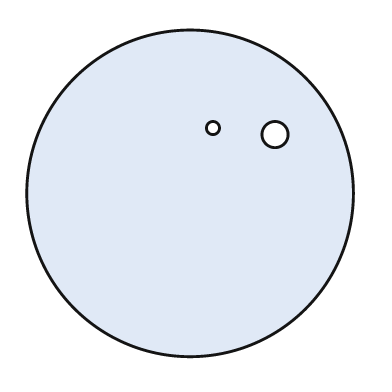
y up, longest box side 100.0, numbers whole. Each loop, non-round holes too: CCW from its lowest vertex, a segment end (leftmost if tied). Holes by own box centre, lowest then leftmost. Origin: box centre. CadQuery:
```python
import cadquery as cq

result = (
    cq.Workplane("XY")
    .moveTo(0.0, 0.0)
    .circle(50.0)
    .moveTo(26.0, 18.0)
    .circle(4.0)
    .moveTo(7.0, 20.0)
    .circle(2.0)
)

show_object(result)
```